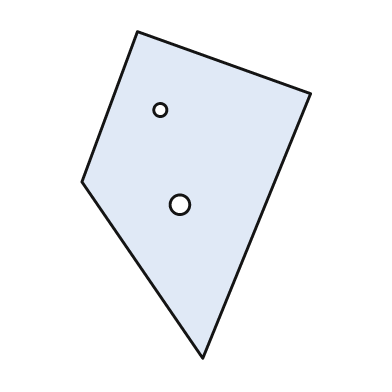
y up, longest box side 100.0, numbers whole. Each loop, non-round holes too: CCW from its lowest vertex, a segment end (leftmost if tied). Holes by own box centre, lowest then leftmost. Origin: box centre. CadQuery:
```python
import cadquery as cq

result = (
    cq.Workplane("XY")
    .moveTo(2.0, -50.0)
    .lineTo(35.0, 31.0)
    .lineTo(-18.0, 50.0)
    .lineTo(-35.0, 4.0)
    .close()
    .moveTo(-5.0, -3.0)
    .circle(3.0)
    .moveTo(-11.0, 26.0)
    .circle(2.0)
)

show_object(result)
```